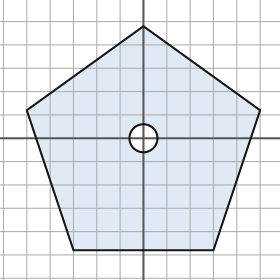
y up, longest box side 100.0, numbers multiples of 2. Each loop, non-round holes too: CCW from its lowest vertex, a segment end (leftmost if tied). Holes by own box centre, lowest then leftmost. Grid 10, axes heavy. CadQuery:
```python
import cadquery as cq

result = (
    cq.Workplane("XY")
    .moveTo(-30.0, -48.0)
    .lineTo(30.0, -48.0)
    .lineTo(50.0, 12.0)
    .lineTo(0.0, 48.0)
    .lineTo(-50.0, 12.0)
    .close()
    .moveTo(0.0, 0.0)
    .circle(6.0)
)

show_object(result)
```